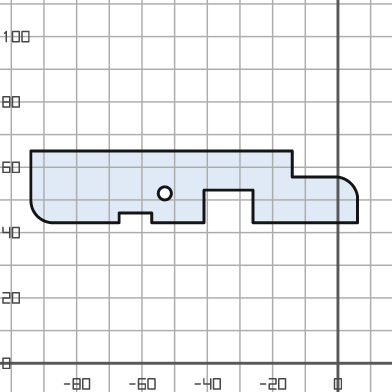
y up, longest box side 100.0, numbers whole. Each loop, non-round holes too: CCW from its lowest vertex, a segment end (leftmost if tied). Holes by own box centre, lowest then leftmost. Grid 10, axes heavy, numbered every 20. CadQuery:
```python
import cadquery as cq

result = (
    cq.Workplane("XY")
    .moveTo(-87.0, 43.0)
    .lineTo(-67.0, 43.0)
    .lineTo(-67.0, 46.0)
    .lineTo(-57.0, 46.0)
    .lineTo(-57.0, 43.0)
    .lineTo(-41.0, 43.0)
    .lineTo(-41.0, 53.0)
    .lineTo(-26.0, 53.0)
    .lineTo(-26.0, 43.0)
    .lineTo(6.0, 43.0)
    .lineTo(6.0, 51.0)
    .threePointArc((4.0, 55.0), (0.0, 57.0))
    .lineTo(-14.0, 57.0)
    .lineTo(-14.0, 65.0)
    .lineTo(-94.0, 65.0)
    .lineTo(-94.0, 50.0)
    .threePointArc((-92.0, 45.0), (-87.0, 43.0))
    .close()
    .moveTo(-53.0, 52.0)
    .circle(2.0)
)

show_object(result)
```